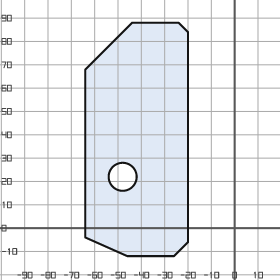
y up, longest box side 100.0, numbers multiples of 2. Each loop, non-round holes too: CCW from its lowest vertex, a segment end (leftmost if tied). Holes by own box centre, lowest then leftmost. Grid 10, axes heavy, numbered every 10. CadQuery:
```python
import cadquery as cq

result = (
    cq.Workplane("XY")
    .moveTo(-46.0, -12.0)
    .lineTo(-26.0, -12.0)
    .lineTo(-20.0, -6.0)
    .lineTo(-20.0, 84.0)
    .lineTo(-24.0, 88.0)
    .lineTo(-44.0, 88.0)
    .lineTo(-64.0, 68.0)
    .lineTo(-64.0, -4.0)
    .close()
    .moveTo(-48.0, 22.0)
    .circle(6.0)
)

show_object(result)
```